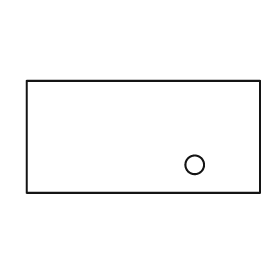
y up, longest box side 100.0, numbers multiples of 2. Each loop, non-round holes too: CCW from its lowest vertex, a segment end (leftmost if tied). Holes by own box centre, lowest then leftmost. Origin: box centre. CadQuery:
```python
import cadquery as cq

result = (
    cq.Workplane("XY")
    .moveTo(-50.0, -24.0)
    .lineTo(50.0, -24.0)
    .lineTo(50.0, 24.0)
    .lineTo(-50.0, 24.0)
    .close()
    .moveTo(22.0, -12.0)
    .circle(4.0)
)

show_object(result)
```